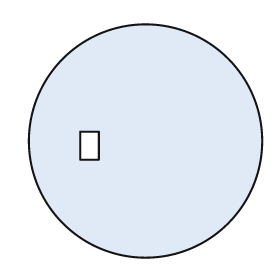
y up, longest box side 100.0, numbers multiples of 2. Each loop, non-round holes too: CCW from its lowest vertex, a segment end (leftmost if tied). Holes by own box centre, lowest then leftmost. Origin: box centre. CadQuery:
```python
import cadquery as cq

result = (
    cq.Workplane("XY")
    .moveTo(0.0, 0.0)
    .circle(50.0)
    .moveTo(-28.0, -8.0)
    .lineTo(-20.0, -8.0)
    .lineTo(-20.0, 4.0)
    .lineTo(-28.0, 4.0)
    .close()
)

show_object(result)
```